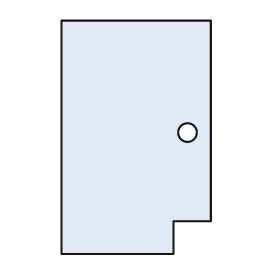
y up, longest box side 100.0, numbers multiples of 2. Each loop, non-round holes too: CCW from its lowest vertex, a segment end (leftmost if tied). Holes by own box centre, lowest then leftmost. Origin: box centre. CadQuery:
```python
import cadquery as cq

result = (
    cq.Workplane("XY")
    .moveTo(-32.0, -50.0)
    .lineTo(16.0, -50.0)
    .lineTo(16.0, -36.0)
    .lineTo(32.0, -36.0)
    .lineTo(32.0, 50.0)
    .lineTo(-32.0, 50.0)
    .close()
    .moveTo(22.0, 2.0)
    .circle(4.0)
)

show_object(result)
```